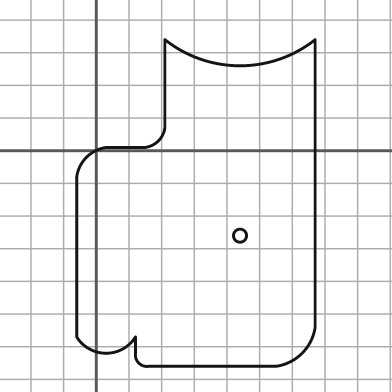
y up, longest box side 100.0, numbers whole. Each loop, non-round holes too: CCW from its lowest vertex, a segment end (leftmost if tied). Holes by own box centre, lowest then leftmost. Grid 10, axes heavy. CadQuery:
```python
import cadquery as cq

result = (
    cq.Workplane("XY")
    .moveTo(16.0, -66.0)
    .lineTo(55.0, -66.0)
    .threePointArc((63.0, -62.0), (67.0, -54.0))
    .lineTo(67.0, 34.0)
    .threePointArc((44.0, 26.0), (21.0, 34.0))
    .lineTo(21.0, 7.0)
    .threePointArc((19.0, 3.0), (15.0, 1.0))
    .lineTo(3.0, 1.0)
    .threePointArc((-3.0, -2.0), (-6.0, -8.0))
    .lineTo(-6.0, -57.0)
    .threePointArc((3.0, -62.0), (12.0, -57.0))
    .lineTo(12.0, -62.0)
    .threePointArc((13.0, -65.0), (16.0, -66.0))
    .close()
    .moveTo(44.0, -26.0)
    .circle(2.0)
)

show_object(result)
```